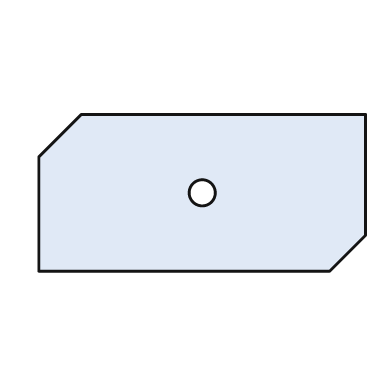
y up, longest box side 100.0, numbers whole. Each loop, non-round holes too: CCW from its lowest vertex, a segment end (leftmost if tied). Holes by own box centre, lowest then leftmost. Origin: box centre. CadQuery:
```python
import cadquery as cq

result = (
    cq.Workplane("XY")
    .moveTo(-50.0, -24.0)
    .lineTo(39.0, -24.0)
    .lineTo(50.0, -13.0)
    .lineTo(50.0, 24.0)
    .lineTo(-37.0, 24.0)
    .lineTo(-50.0, 11.0)
    .close()
    .moveTo(0.0, 0.0)
    .circle(4.0)
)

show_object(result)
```